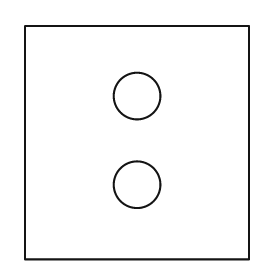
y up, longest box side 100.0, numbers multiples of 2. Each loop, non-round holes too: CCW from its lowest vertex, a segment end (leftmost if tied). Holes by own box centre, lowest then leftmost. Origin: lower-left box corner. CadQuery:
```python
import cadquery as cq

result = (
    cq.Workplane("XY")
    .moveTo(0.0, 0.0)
    .lineTo(96.0, 0.0)
    .lineTo(96.0, 100.0)
    .lineTo(0.0, 100.0)
    .close()
    .moveTo(48.0, 32.0)
    .circle(10.0)
    .moveTo(48.0, 70.0)
    .circle(10.0)
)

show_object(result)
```